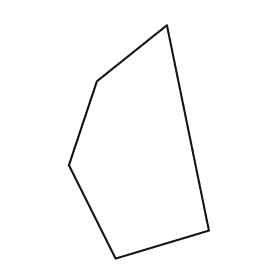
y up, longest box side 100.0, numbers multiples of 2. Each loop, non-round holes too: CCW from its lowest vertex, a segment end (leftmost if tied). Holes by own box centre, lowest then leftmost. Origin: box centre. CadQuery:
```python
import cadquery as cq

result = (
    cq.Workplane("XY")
    .moveTo(-10.0, -50.0)
    .lineTo(30.0, -38.0)
    .lineTo(12.0, 50.0)
    .lineTo(-18.0, 26.0)
    .lineTo(-30.0, -10.0)
    .close()
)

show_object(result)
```